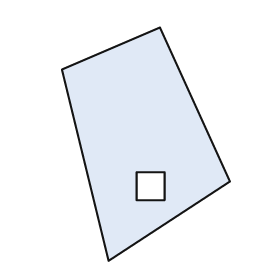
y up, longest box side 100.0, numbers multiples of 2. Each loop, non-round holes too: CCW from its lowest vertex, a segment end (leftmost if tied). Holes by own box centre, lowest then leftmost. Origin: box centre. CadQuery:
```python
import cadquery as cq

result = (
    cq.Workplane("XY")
    .moveTo(-16.0, -50.0)
    .lineTo(36.0, -16.0)
    .lineTo(6.0, 50.0)
    .lineTo(-36.0, 32.0)
    .close()
    .moveTo(-4.0, -24.0)
    .lineTo(8.0, -24.0)
    .lineTo(8.0, -12.0)
    .lineTo(-4.0, -12.0)
    .close()
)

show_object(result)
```